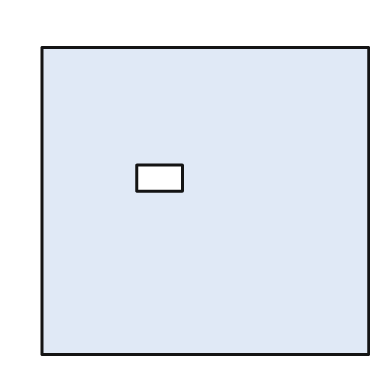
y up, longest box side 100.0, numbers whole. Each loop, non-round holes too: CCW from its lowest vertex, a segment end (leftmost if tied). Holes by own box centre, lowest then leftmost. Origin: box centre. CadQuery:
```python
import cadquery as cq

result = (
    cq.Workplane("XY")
    .moveTo(-50.0, -47.0)
    .lineTo(50.0, -47.0)
    .lineTo(50.0, 47.0)
    .lineTo(-50.0, 47.0)
    .close()
    .moveTo(-21.0, 3.0)
    .lineTo(-7.0, 3.0)
    .lineTo(-7.0, 11.0)
    .lineTo(-21.0, 11.0)
    .close()
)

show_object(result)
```